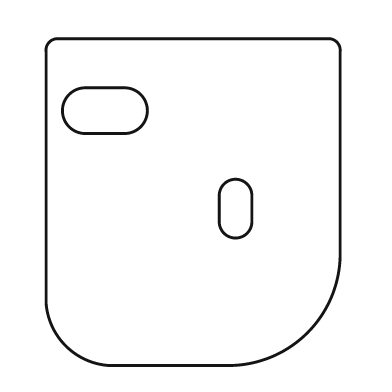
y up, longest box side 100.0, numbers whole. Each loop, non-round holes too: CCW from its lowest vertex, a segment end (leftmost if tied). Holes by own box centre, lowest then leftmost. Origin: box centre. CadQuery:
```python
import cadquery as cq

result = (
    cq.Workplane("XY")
    .moveTo(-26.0, -50.0)
    .lineTo(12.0, -50.0)
    .threePointArc((35.0, -40.0), (45.0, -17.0))
    .lineTo(45.0, 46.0)
    .threePointArc((44.0, 49.0), (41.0, 50.0))
    .lineTo(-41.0, 50.0)
    .threePointArc((-44.0, 49.0), (-45.0, 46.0))
    .lineTo(-45.0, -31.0)
    .threePointArc((-39.0, -44.0), (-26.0, -50.0))
    .close()
    .moveTo(8.0, -6.0)
    .threePointArc((13.0, -11.0), (18.0, -6.0))
    .lineTo(18.0, 2.0)
    .threePointArc((13.0, 7.0), (8.0, 2.0))
    .close()
    .moveTo(-33.0, 21.0)
    .lineTo(-21.0, 21.0)
    .threePointArc((-14.0, 28.0), (-21.0, 35.0))
    .lineTo(-33.0, 35.0)
    .threePointArc((-40.0, 28.0), (-33.0, 21.0))
    .close()
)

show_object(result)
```